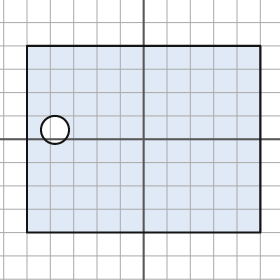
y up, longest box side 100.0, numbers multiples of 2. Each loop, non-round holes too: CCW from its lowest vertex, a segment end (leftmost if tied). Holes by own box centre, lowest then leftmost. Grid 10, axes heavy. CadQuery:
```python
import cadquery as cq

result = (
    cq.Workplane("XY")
    .moveTo(-50.0, -40.0)
    .lineTo(50.0, -40.0)
    .lineTo(50.0, 40.0)
    .lineTo(-50.0, 40.0)
    .close()
    .moveTo(-38.0, 4.0)
    .circle(6.0)
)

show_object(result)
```